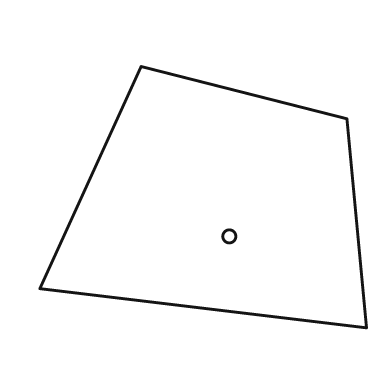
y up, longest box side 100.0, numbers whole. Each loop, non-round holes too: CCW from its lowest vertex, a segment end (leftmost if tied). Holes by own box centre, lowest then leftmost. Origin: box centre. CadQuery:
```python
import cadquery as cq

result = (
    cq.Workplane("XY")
    .moveTo(50.0, -40.0)
    .lineTo(44.0, 24.0)
    .lineTo(-19.0, 40.0)
    .lineTo(-50.0, -28.0)
    .close()
    .moveTo(8.0, -12.0)
    .circle(2.0)
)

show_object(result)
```